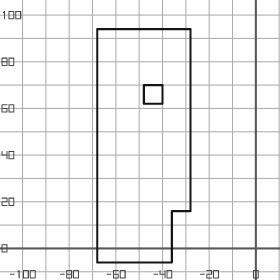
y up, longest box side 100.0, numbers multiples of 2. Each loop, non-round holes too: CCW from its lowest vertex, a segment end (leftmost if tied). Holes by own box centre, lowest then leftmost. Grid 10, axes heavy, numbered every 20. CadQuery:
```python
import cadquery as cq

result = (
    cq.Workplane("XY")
    .moveTo(-68.0, -6.0)
    .lineTo(-36.0, -6.0)
    .lineTo(-36.0, 16.0)
    .lineTo(-28.0, 16.0)
    .lineTo(-28.0, 94.0)
    .lineTo(-68.0, 94.0)
    .close()
    .moveTo(-48.0, 62.0)
    .lineTo(-40.0, 62.0)
    .lineTo(-40.0, 70.0)
    .lineTo(-48.0, 70.0)
    .close()
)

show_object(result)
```